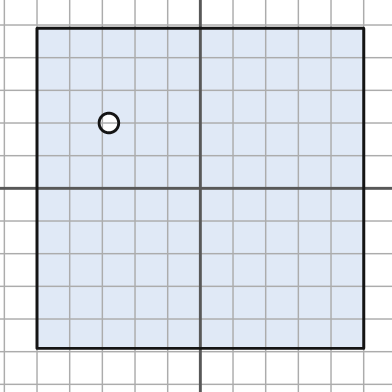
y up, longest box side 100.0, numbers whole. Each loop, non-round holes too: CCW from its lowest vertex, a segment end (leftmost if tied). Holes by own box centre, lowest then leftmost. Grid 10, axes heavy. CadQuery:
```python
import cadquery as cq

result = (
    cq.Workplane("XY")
    .moveTo(-50.0, -49.0)
    .lineTo(50.0, -49.0)
    .lineTo(50.0, 49.0)
    .lineTo(-50.0, 49.0)
    .close()
    .moveTo(-28.0, 20.0)
    .circle(3.0)
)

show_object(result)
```